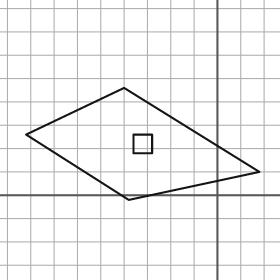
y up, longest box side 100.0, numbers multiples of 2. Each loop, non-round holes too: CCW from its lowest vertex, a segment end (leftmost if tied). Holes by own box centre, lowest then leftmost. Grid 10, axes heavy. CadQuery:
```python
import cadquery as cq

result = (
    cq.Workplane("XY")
    .moveTo(-38.0, -2.0)
    .lineTo(18.0, 10.0)
    .lineTo(-40.0, 46.0)
    .lineTo(-82.0, 26.0)
    .close()
    .moveTo(-36.0, 18.0)
    .lineTo(-28.0, 18.0)
    .lineTo(-28.0, 26.0)
    .lineTo(-36.0, 26.0)
    .close()
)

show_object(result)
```